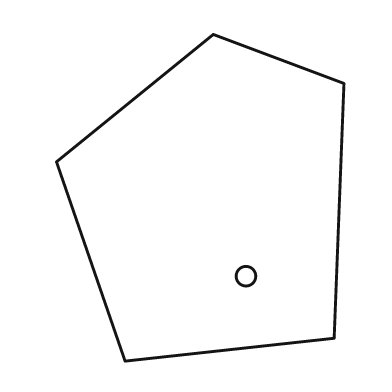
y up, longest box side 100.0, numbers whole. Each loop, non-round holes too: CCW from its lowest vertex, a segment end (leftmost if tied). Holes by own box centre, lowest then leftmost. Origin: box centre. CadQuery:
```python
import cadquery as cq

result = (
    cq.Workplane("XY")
    .moveTo(-23.0, -50.0)
    .lineTo(41.0, -43.0)
    .lineTo(44.0, 35.0)
    .lineTo(4.0, 50.0)
    .lineTo(-44.0, 11.0)
    .close()
    .moveTo(14.0, -24.0)
    .circle(3.0)
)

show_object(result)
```